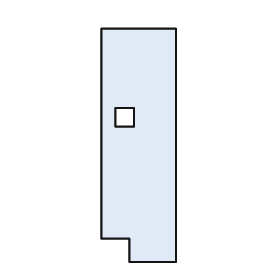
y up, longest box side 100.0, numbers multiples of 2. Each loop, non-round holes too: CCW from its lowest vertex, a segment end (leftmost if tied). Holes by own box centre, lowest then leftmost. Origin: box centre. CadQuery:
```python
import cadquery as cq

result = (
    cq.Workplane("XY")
    .moveTo(-4.0, -50.0)
    .lineTo(16.0, -50.0)
    .lineTo(16.0, 50.0)
    .lineTo(-16.0, 50.0)
    .lineTo(-16.0, -40.0)
    .lineTo(-4.0, -40.0)
    .close()
    .moveTo(-10.0, 8.0)
    .lineTo(-2.0, 8.0)
    .lineTo(-2.0, 16.0)
    .lineTo(-10.0, 16.0)
    .close()
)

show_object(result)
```